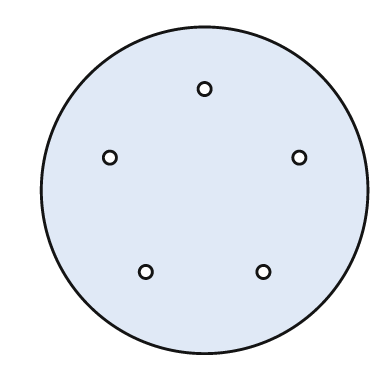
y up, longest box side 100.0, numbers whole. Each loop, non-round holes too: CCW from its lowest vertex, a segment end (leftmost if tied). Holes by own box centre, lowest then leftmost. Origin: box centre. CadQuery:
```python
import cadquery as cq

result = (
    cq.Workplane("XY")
    .moveTo(0.0, 0.0)
    .circle(50.0)
    .moveTo(-18.0, -25.0)
    .circle(2.0)
    .moveTo(18.0, -25.0)
    .circle(2.0)
    .moveTo(-29.0, 10.0)
    .circle(2.0)
    .moveTo(29.0, 10.0)
    .circle(2.0)
    .moveTo(0.0, 31.0)
    .circle(2.0)
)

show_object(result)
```